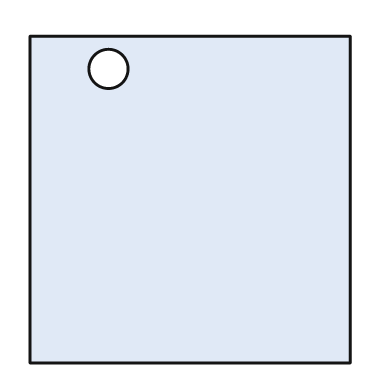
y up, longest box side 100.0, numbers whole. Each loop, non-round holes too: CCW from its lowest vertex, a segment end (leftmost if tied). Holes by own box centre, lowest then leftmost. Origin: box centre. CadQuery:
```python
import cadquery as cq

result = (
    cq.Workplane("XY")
    .moveTo(-49.0, -50.0)
    .lineTo(49.0, -50.0)
    .lineTo(49.0, 50.0)
    .lineTo(-49.0, 50.0)
    .close()
    .moveTo(-25.0, 40.0)
    .circle(6.0)
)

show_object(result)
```